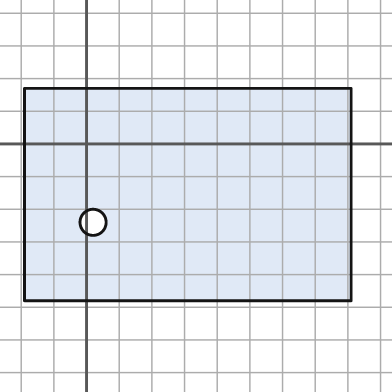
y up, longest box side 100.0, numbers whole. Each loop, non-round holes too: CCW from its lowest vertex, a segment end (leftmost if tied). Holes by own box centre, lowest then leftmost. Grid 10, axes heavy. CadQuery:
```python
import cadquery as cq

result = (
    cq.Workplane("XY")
    .moveTo(-19.0, -48.0)
    .lineTo(81.0, -48.0)
    .lineTo(81.0, 17.0)
    .lineTo(-19.0, 17.0)
    .close()
    .moveTo(2.0, -24.0)
    .circle(4.0)
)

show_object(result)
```